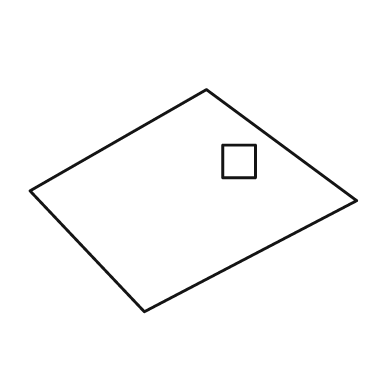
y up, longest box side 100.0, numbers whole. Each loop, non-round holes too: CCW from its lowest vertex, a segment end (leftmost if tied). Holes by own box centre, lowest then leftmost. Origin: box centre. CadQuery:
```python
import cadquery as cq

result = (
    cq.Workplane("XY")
    .moveTo(-15.0, -34.0)
    .lineTo(50.0, 0.0)
    .lineTo(4.0, 34.0)
    .lineTo(-50.0, 3.0)
    .close()
    .moveTo(9.0, 7.0)
    .lineTo(19.0, 7.0)
    .lineTo(19.0, 17.0)
    .lineTo(9.0, 17.0)
    .close()
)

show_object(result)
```